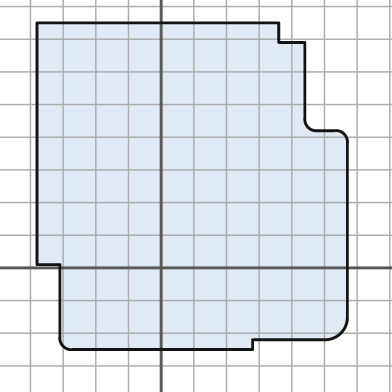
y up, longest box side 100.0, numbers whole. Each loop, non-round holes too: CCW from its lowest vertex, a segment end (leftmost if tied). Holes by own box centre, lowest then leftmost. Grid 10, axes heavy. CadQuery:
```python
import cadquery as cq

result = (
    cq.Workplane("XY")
    .moveTo(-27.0, -25.0)
    .lineTo(28.0, -25.0)
    .lineTo(28.0, -22.0)
    .lineTo(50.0, -22.0)
    .threePointArc((55.0, -20.0), (57.0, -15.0))
    .lineTo(57.0, 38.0)
    .threePointArc((56.0, 41.0), (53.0, 42.0))
    .lineTo(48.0, 42.0)
    .threePointArc((45.0, 43.0), (44.0, 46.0))
    .lineTo(44.0, 69.0)
    .lineTo(36.0, 69.0)
    .lineTo(36.0, 75.0)
    .lineTo(-38.0, 75.0)
    .lineTo(-38.0, 1.0)
    .lineTo(-31.0, 1.0)
    .lineTo(-31.0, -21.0)
    .threePointArc((-30.0, -24.0), (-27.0, -25.0))
    .close()
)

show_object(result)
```